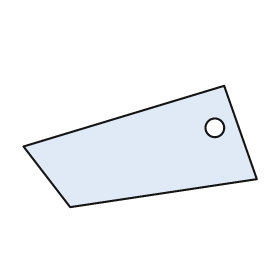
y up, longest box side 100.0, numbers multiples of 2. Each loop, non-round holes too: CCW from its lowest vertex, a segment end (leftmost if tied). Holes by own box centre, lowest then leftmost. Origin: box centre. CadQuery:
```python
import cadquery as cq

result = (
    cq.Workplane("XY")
    .moveTo(-30.0, -26.0)
    .lineTo(50.0, -14.0)
    .lineTo(36.0, 26.0)
    .lineTo(-50.0, 0.0)
    .close()
    .moveTo(32.0, 8.0)
    .circle(4.0)
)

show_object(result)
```